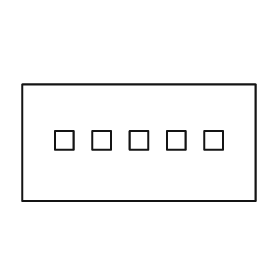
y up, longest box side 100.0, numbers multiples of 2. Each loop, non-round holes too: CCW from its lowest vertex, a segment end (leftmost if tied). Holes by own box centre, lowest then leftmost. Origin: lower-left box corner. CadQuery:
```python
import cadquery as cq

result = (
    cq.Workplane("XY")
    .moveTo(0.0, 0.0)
    .lineTo(100.0, 0.0)
    .lineTo(100.0, 50.0)
    .lineTo(0.0, 50.0)
    .close()
    .moveTo(14.0, 22.0)
    .lineTo(22.0, 22.0)
    .lineTo(22.0, 30.0)
    .lineTo(14.0, 30.0)
    .close()
    .moveTo(30.0, 22.0)
    .lineTo(38.0, 22.0)
    .lineTo(38.0, 30.0)
    .lineTo(30.0, 30.0)
    .close()
    .moveTo(46.0, 22.0)
    .lineTo(54.0, 22.0)
    .lineTo(54.0, 30.0)
    .lineTo(46.0, 30.0)
    .close()
    .moveTo(62.0, 22.0)
    .lineTo(70.0, 22.0)
    .lineTo(70.0, 30.0)
    .lineTo(62.0, 30.0)
    .close()
    .moveTo(78.0, 22.0)
    .lineTo(86.0, 22.0)
    .lineTo(86.0, 30.0)
    .lineTo(78.0, 30.0)
    .close()
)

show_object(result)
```